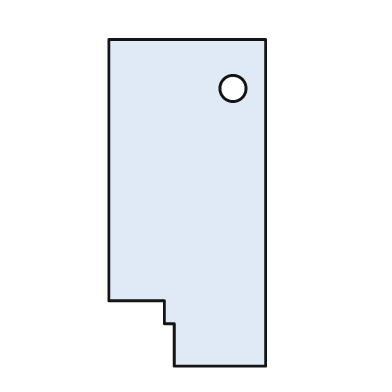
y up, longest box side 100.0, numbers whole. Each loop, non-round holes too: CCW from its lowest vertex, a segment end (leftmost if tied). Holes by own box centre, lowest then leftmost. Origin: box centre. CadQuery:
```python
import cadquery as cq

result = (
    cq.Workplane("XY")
    .moveTo(-4.0, -50.0)
    .lineTo(24.0, -50.0)
    .lineTo(24.0, 50.0)
    .lineTo(-24.0, 50.0)
    .lineTo(-24.0, -30.0)
    .lineTo(-7.0, -30.0)
    .lineTo(-7.0, -37.0)
    .lineTo(-4.0, -37.0)
    .close()
    .moveTo(14.0, 35.0)
    .circle(4.0)
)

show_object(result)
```